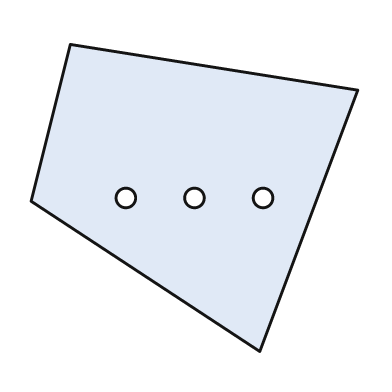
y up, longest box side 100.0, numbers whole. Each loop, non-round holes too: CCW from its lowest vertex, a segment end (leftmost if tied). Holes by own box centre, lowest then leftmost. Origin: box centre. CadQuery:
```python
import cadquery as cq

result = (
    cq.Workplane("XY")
    .moveTo(20.0, -47.0)
    .lineTo(50.0, 33.0)
    .lineTo(-38.0, 47.0)
    .lineTo(-50.0, -1.0)
    .close()
    .moveTo(-21.0, 0.0)
    .circle(3.0)
    .moveTo(0.0, 0.0)
    .circle(3.0)
    .moveTo(21.0, 0.0)
    .circle(3.0)
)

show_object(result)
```